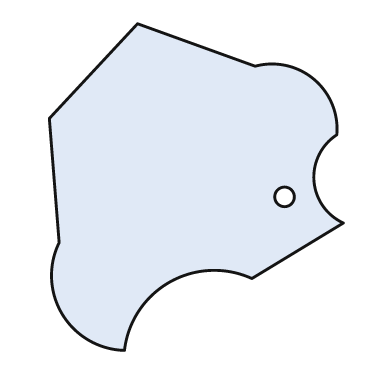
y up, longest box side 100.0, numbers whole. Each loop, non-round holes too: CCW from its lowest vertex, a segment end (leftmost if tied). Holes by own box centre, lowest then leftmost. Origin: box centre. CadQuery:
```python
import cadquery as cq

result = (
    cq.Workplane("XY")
    .moveTo(-22.0, -50.0)
    .threePointArc((-8.0, -29.0), (17.0, -28.0))
    .lineTo(45.0, -11.0)
    .threePointArc((36.0, 2.0), (43.0, 16.0))
    .threePointArc((36.0, 33.0), (18.0, 37.0))
    .lineTo(-18.0, 50.0)
    .lineTo(-45.0, 21.0)
    .lineTo(-42.0, -17.0)
    .threePointArc((-41.0, -39.0), (-22.0, -50.0))
    .close()
    .moveTo(27.0, -3.0)
    .circle(3.0)
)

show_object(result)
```